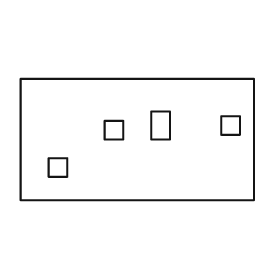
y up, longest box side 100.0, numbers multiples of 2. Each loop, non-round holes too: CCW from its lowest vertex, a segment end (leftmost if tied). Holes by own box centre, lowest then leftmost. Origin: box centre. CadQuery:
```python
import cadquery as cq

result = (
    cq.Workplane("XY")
    .moveTo(-50.0, -26.0)
    .lineTo(50.0, -26.0)
    .lineTo(50.0, 26.0)
    .lineTo(-50.0, 26.0)
    .close()
    .moveTo(-38.0, -16.0)
    .lineTo(-30.0, -16.0)
    .lineTo(-30.0, -8.0)
    .lineTo(-38.0, -8.0)
    .close()
    .moveTo(-14.0, 0.0)
    .lineTo(-6.0, 0.0)
    .lineTo(-6.0, 8.0)
    .lineTo(-14.0, 8.0)
    .close()
    .moveTo(6.0, 0.0)
    .lineTo(14.0, 0.0)
    .lineTo(14.0, 12.0)
    .lineTo(6.0, 12.0)
    .close()
    .moveTo(36.0, 2.0)
    .lineTo(44.0, 2.0)
    .lineTo(44.0, 10.0)
    .lineTo(36.0, 10.0)
    .close()
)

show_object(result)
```